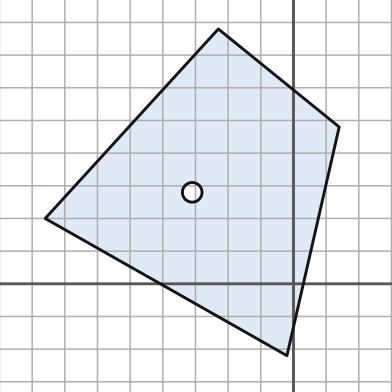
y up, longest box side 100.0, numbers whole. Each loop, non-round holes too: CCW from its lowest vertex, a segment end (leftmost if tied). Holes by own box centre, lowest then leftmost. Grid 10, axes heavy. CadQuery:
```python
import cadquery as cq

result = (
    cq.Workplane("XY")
    .moveTo(-2.0, -22.0)
    .lineTo(14.0, 48.0)
    .lineTo(-23.0, 78.0)
    .lineTo(-76.0, 20.0)
    .close()
    .moveTo(-31.0, 28.0)
    .circle(3.0)
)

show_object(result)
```